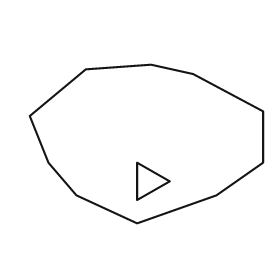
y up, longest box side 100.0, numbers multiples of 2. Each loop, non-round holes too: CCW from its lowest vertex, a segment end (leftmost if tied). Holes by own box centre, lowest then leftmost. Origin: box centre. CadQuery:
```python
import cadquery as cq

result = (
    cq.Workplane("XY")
    .moveTo(-4.0, -34.0)
    .lineTo(30.0, -22.0)
    .lineTo(50.0, -8.0)
    .lineTo(50.0, 14.0)
    .lineTo(20.0, 30.0)
    .lineTo(2.0, 34.0)
    .lineTo(-26.0, 32.0)
    .lineTo(-50.0, 12.0)
    .lineTo(-42.0, -8.0)
    .lineTo(-30.0, -22.0)
    .close()
    .moveTo(-4.0, -24.0)
    .lineTo(10.0, -16.0)
    .lineTo(-4.0, -8.0)
    .close()
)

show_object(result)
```